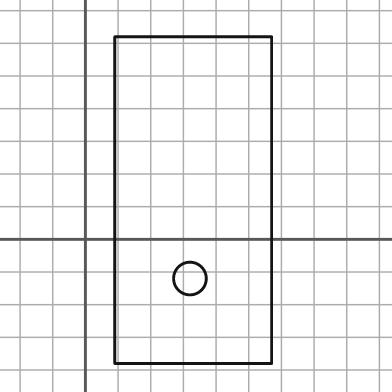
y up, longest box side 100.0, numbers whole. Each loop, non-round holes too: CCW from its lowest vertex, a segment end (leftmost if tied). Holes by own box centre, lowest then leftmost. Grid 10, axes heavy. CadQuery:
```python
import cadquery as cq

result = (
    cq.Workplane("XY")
    .moveTo(9.0, -38.0)
    .lineTo(57.0, -38.0)
    .lineTo(57.0, 62.0)
    .lineTo(9.0, 62.0)
    .close()
    .moveTo(32.0, -12.0)
    .circle(5.0)
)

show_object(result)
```